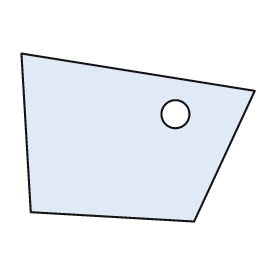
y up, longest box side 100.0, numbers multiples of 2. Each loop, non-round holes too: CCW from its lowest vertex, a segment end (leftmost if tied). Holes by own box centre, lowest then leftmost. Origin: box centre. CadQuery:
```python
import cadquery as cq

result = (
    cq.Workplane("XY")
    .moveTo(24.0, -36.0)
    .lineTo(50.0, 20.0)
    .lineTo(-50.0, 36.0)
    .lineTo(-46.0, -32.0)
    .close()
    .moveTo(16.0, 10.0)
    .circle(6.0)
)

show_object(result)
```